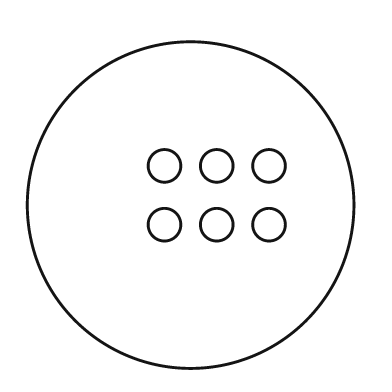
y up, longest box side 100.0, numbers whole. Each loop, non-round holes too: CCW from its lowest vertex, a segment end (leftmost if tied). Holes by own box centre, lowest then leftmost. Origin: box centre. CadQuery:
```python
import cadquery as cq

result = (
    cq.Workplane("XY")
    .moveTo(0.0, 0.0)
    .circle(50.0)
    .moveTo(-8.0, -6.0)
    .circle(5.0)
    .moveTo(8.0, -6.0)
    .circle(5.0)
    .moveTo(24.0, -6.0)
    .circle(5.0)
    .moveTo(-8.0, 12.0)
    .circle(5.0)
    .moveTo(8.0, 12.0)
    .circle(5.0)
    .moveTo(24.0, 12.0)
    .circle(5.0)
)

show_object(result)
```